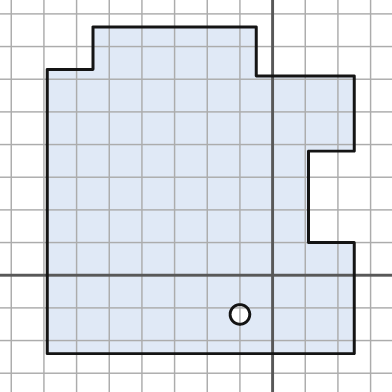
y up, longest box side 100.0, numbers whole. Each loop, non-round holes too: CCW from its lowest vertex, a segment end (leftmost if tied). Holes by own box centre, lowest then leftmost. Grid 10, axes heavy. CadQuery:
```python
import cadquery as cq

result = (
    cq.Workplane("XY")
    .moveTo(-69.0, -24.0)
    .lineTo(25.0, -24.0)
    .lineTo(25.0, 10.0)
    .lineTo(11.0, 10.0)
    .lineTo(11.0, 38.0)
    .lineTo(25.0, 38.0)
    .lineTo(25.0, 61.0)
    .lineTo(-5.0, 61.0)
    .lineTo(-5.0, 76.0)
    .lineTo(-55.0, 76.0)
    .lineTo(-55.0, 63.0)
    .lineTo(-69.0, 63.0)
    .close()
    .moveTo(-10.0, -12.0)
    .circle(3.0)
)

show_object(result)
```